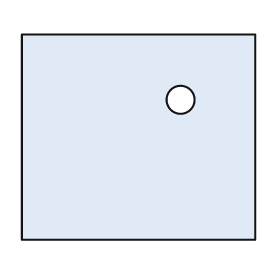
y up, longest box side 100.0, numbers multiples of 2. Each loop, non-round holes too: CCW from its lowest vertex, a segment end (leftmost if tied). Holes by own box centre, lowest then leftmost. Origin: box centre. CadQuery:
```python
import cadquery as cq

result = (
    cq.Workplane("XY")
    .moveTo(-50.0, -44.0)
    .lineTo(50.0, -44.0)
    .lineTo(50.0, 44.0)
    .lineTo(-50.0, 44.0)
    .close()
    .moveTo(18.0, 16.0)
    .circle(6.0)
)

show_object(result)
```